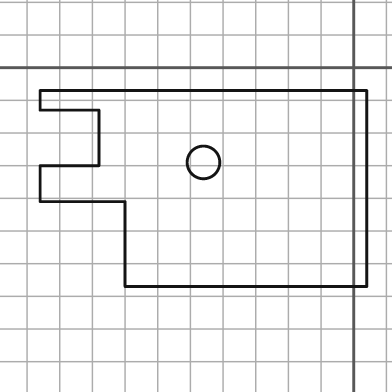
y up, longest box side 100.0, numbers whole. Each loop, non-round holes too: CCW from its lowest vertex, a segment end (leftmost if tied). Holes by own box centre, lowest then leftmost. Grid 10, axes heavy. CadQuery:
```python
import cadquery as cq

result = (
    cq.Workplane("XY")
    .moveTo(-70.0, -67.0)
    .lineTo(4.0, -67.0)
    .lineTo(4.0, -7.0)
    .lineTo(-96.0, -7.0)
    .lineTo(-96.0, -13.0)
    .lineTo(-78.0, -13.0)
    .lineTo(-78.0, -30.0)
    .lineTo(-96.0, -30.0)
    .lineTo(-96.0, -41.0)
    .lineTo(-70.0, -41.0)
    .close()
    .moveTo(-46.0, -29.0)
    .circle(5.0)
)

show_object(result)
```